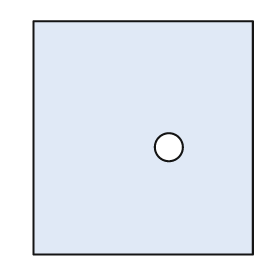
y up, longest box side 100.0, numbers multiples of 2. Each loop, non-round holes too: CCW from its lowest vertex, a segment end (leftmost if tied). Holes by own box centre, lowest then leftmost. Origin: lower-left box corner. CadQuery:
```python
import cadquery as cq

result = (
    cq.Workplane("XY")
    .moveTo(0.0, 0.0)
    .lineTo(94.0, 0.0)
    .lineTo(94.0, 100.0)
    .lineTo(0.0, 100.0)
    .close()
    .moveTo(58.0, 46.0)
    .circle(6.0)
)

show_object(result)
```